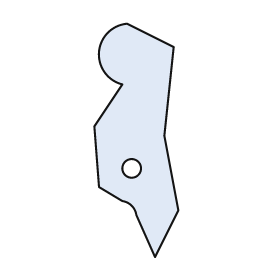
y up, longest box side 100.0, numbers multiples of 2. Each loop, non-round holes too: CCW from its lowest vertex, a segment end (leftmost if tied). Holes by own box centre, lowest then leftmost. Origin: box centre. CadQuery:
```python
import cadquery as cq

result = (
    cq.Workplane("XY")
    .moveTo(8.0, -50.0)
    .lineTo(18.0, -30.0)
    .lineTo(12.0, 2.0)
    .lineTo(16.0, 40.0)
    .lineTo(-4.0, 50.0)
    .threePointArc((-16.0, 38.0), (-6.0, 24.0))
    .lineTo(-18.0, 6.0)
    .lineTo(-16.0, -20.0)
    .lineTo(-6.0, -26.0)
    .threePointArc((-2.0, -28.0), (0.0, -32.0))
    .close()
    .moveTo(-2.0, -12.0)
    .circle(4.0)
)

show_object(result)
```